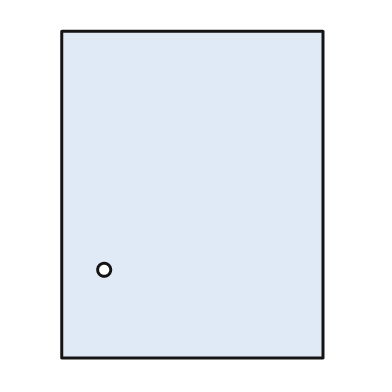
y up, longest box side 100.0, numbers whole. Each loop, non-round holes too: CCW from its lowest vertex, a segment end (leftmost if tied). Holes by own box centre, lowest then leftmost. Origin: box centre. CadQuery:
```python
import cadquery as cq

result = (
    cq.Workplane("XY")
    .moveTo(-40.0, -50.0)
    .lineTo(40.0, -50.0)
    .lineTo(40.0, 50.0)
    .lineTo(-40.0, 50.0)
    .close()
    .moveTo(-27.0, -23.0)
    .circle(2.0)
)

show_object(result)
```